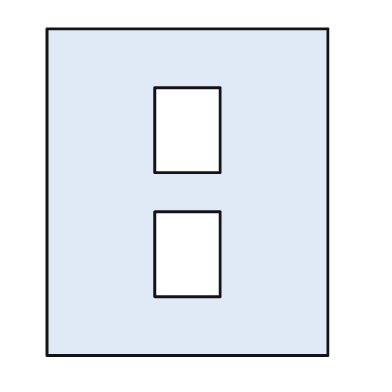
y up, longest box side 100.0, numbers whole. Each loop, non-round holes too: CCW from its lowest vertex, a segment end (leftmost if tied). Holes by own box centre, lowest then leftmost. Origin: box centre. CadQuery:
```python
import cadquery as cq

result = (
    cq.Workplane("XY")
    .moveTo(-43.0, -50.0)
    .lineTo(43.0, -50.0)
    .lineTo(43.0, 50.0)
    .lineTo(-43.0, 50.0)
    .close()
    .moveTo(-10.0, -32.0)
    .lineTo(10.0, -32.0)
    .lineTo(10.0, -6.0)
    .lineTo(-10.0, -6.0)
    .close()
    .moveTo(-10.0, 6.0)
    .lineTo(10.0, 6.0)
    .lineTo(10.0, 32.0)
    .lineTo(-10.0, 32.0)
    .close()
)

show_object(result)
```